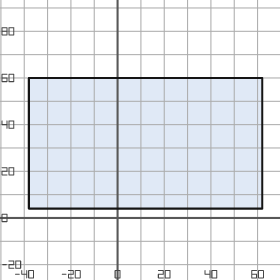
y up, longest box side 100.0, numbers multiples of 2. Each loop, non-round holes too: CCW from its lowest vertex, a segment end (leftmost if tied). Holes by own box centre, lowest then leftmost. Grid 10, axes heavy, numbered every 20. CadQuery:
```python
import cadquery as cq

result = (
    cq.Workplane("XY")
    .moveTo(-38.0, 4.0)
    .lineTo(62.0, 4.0)
    .lineTo(62.0, 60.0)
    .lineTo(-38.0, 60.0)
    .close()
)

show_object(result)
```